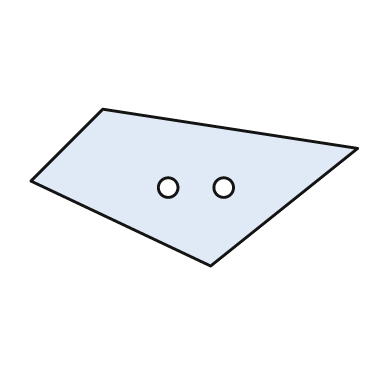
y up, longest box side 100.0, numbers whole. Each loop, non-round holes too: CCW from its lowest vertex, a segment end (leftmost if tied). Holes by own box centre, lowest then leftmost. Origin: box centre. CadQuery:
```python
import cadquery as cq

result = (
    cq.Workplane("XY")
    .moveTo(5.0, -24.0)
    .lineTo(50.0, 12.0)
    .lineTo(-28.0, 24.0)
    .lineTo(-50.0, 2.0)
    .close()
    .moveTo(-8.0, 0.0)
    .circle(3.0)
    .moveTo(9.0, 0.0)
    .circle(3.0)
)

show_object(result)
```